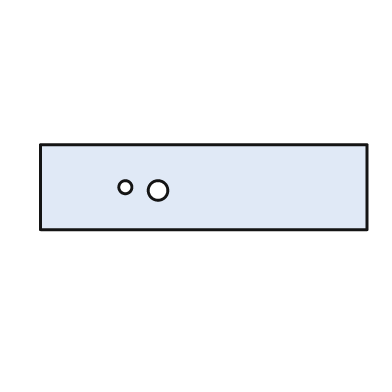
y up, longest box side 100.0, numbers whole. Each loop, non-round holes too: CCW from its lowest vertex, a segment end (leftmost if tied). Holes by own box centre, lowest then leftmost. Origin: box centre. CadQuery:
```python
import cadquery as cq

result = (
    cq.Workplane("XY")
    .moveTo(-50.0, -13.0)
    .lineTo(50.0, -13.0)
    .lineTo(50.0, 13.0)
    .lineTo(-50.0, 13.0)
    .close()
    .moveTo(-14.0, -1.0)
    .circle(3.0)
    .moveTo(-24.0, 0.0)
    .circle(2.0)
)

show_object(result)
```